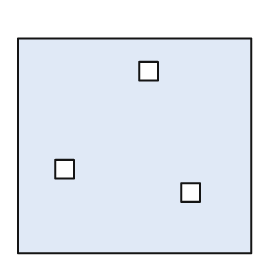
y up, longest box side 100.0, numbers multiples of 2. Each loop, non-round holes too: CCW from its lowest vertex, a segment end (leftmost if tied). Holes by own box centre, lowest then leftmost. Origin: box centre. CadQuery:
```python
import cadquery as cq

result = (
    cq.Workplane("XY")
    .moveTo(-50.0, -46.0)
    .lineTo(50.0, -46.0)
    .lineTo(50.0, 46.0)
    .lineTo(-50.0, 46.0)
    .close()
    .moveTo(20.0, -24.0)
    .lineTo(28.0, -24.0)
    .lineTo(28.0, -16.0)
    .lineTo(20.0, -16.0)
    .close()
    .moveTo(-34.0, -14.0)
    .lineTo(-26.0, -14.0)
    .lineTo(-26.0, -6.0)
    .lineTo(-34.0, -6.0)
    .close()
    .moveTo(2.0, 28.0)
    .lineTo(10.0, 28.0)
    .lineTo(10.0, 36.0)
    .lineTo(2.0, 36.0)
    .close()
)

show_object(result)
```